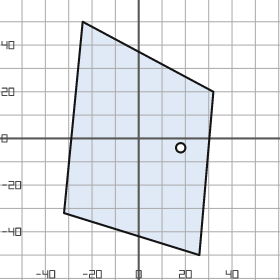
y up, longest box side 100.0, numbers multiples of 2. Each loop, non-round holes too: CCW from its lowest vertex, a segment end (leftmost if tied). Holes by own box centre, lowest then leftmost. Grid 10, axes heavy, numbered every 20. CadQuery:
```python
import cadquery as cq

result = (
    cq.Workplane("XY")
    .moveTo(26.0, -50.0)
    .lineTo(32.0, 20.0)
    .lineTo(-24.0, 50.0)
    .lineTo(-32.0, -32.0)
    .close()
    .moveTo(18.0, -4.0)
    .circle(2.0)
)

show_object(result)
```